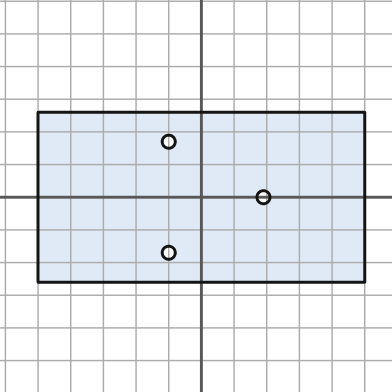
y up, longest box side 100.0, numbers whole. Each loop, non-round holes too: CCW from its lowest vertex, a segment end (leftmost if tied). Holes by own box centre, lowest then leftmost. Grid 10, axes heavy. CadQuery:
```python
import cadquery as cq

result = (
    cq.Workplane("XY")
    .moveTo(-50.0, -26.0)
    .lineTo(50.0, -26.0)
    .lineTo(50.0, 26.0)
    .lineTo(-50.0, 26.0)
    .close()
    .moveTo(-10.0, -17.0)
    .circle(2.0)
    .moveTo(19.0, 0.0)
    .circle(2.0)
    .moveTo(-10.0, 17.0)
    .circle(2.0)
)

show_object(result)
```